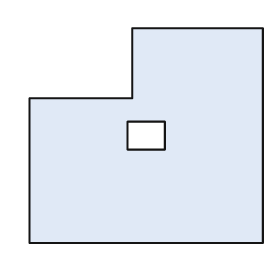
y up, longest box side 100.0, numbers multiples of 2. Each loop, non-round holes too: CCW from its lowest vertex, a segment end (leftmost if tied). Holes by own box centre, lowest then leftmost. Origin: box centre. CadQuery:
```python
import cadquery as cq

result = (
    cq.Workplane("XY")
    .moveTo(-50.0, -46.0)
    .lineTo(50.0, -46.0)
    .lineTo(50.0, 46.0)
    .lineTo(-6.0, 46.0)
    .lineTo(-6.0, 16.0)
    .lineTo(-50.0, 16.0)
    .close()
    .moveTo(-8.0, -6.0)
    .lineTo(8.0, -6.0)
    .lineTo(8.0, 6.0)
    .lineTo(-8.0, 6.0)
    .close()
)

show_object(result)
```